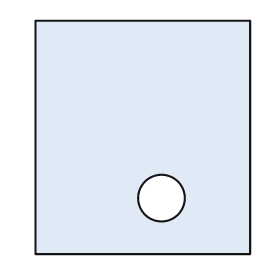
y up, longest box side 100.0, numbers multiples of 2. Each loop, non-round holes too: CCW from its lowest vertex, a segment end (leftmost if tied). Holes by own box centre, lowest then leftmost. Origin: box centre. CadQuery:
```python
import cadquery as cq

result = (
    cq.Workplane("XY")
    .moveTo(-46.0, -50.0)
    .lineTo(46.0, -50.0)
    .lineTo(46.0, 50.0)
    .lineTo(-46.0, 50.0)
    .close()
    .moveTo(8.0, -26.0)
    .circle(10.0)
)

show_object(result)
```